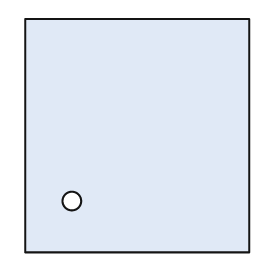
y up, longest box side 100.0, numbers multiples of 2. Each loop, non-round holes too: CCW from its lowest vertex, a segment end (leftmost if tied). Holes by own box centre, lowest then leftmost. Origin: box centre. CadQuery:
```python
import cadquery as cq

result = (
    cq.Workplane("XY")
    .moveTo(-48.0, -50.0)
    .lineTo(48.0, -50.0)
    .lineTo(48.0, 50.0)
    .lineTo(-48.0, 50.0)
    .close()
    .moveTo(-28.0, -28.0)
    .circle(4.0)
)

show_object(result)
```